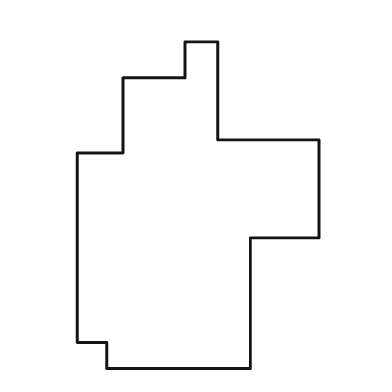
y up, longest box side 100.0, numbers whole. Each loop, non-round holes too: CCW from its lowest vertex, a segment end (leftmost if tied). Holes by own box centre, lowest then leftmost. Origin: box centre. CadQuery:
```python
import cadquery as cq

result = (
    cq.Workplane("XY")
    .moveTo(-28.0, -50.0)
    .lineTo(16.0, -50.0)
    .lineTo(16.0, -10.0)
    .lineTo(37.0, -10.0)
    .lineTo(37.0, 20.0)
    .lineTo(6.0, 20.0)
    .lineTo(6.0, 50.0)
    .lineTo(-4.0, 50.0)
    .lineTo(-4.0, 39.0)
    .lineTo(-23.0, 39.0)
    .lineTo(-23.0, 16.0)
    .lineTo(-37.0, 16.0)
    .lineTo(-37.0, -42.0)
    .lineTo(-28.0, -42.0)
    .close()
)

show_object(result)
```